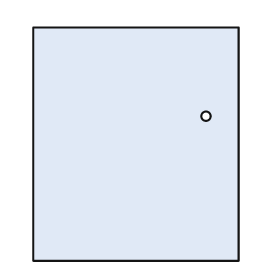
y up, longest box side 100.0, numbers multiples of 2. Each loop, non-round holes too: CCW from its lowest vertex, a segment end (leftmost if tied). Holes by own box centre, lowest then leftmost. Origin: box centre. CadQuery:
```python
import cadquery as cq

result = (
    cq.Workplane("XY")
    .moveTo(-44.0, -50.0)
    .lineTo(44.0, -50.0)
    .lineTo(44.0, 50.0)
    .lineTo(-44.0, 50.0)
    .close()
    .moveTo(30.0, 12.0)
    .circle(2.0)
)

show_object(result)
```